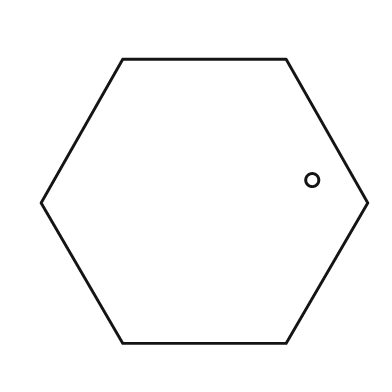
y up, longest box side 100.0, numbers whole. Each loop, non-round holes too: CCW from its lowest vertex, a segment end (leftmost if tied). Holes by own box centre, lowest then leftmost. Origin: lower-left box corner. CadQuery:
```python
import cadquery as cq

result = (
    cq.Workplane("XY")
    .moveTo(25.0, 0.0)
    .lineTo(75.0, 0.0)
    .lineTo(100.0, 43.0)
    .lineTo(75.0, 87.0)
    .lineTo(25.0, 87.0)
    .lineTo(0.0, 43.0)
    .close()
    .moveTo(83.0, 50.0)
    .circle(2.0)
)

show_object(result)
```